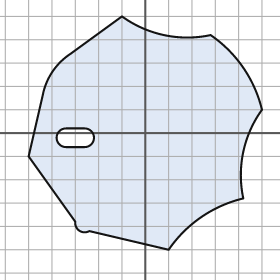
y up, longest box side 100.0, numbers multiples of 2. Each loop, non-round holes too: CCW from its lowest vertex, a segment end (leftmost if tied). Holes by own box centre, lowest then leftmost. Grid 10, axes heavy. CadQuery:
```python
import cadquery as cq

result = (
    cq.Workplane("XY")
    .moveTo(10.0, -50.0)
    .threePointArc((24.0, -36.0), (42.0, -28.0))
    .threePointArc((42.0, -8.0), (50.0, 10.0))
    .threePointArc((42.0, 28.0), (28.0, 42.0))
    .threePointArc((8.0, 42.0), (-10.0, 50.0))
    .lineTo(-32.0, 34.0)
    .threePointArc((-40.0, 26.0), (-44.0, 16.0))
    .lineTo(-50.0, -10.0)
    .lineTo(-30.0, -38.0)
    .threePointArc((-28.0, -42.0), (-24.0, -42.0))
    .close()
    .moveTo(-34.0, -6.0)
    .lineTo(-26.0, -6.0)
    .threePointArc((-22.0, -2.0), (-26.0, 2.0))
    .lineTo(-34.0, 2.0)
    .threePointArc((-38.0, -2.0), (-34.0, -6.0))
    .close()
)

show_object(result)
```